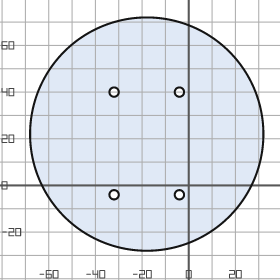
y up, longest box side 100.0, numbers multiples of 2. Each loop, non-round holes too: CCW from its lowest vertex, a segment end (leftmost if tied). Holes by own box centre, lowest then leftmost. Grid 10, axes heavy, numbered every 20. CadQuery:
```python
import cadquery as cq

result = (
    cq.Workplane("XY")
    .moveTo(-18.0, 22.0)
    .circle(50.0)
    .moveTo(-32.0, -4.0)
    .circle(2.0)
    .moveTo(-4.0, -4.0)
    .circle(2.0)
    .moveTo(-32.0, 40.0)
    .circle(2.0)
    .moveTo(-4.0, 40.0)
    .circle(2.0)
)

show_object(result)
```